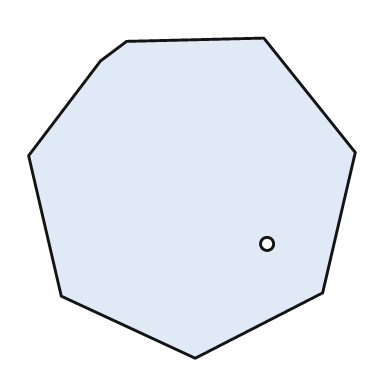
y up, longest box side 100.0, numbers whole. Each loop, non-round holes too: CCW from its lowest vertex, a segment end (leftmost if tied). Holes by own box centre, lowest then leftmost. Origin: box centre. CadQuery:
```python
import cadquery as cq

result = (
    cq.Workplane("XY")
    .moveTo(1.0, -49.0)
    .lineTo(40.0, -29.0)
    .lineTo(50.0, 14.0)
    .lineTo(22.0, 49.0)
    .lineTo(-20.0, 48.0)
    .lineTo(-28.0, 42.0)
    .lineTo(-50.0, 13.0)
    .lineTo(-40.0, -30.0)
    .close()
    .moveTo(23.0, -14.0)
    .circle(2.0)
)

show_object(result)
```